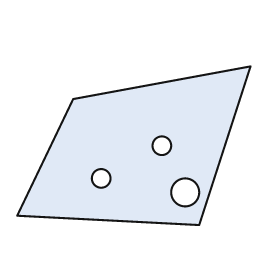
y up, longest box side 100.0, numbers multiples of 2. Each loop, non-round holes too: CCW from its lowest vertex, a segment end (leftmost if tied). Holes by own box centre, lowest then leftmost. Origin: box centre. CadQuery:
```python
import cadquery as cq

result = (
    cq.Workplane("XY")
    .moveTo(28.0, -34.0)
    .lineTo(50.0, 34.0)
    .lineTo(-26.0, 20.0)
    .lineTo(-50.0, -30.0)
    .close()
    .moveTo(22.0, -20.0)
    .circle(6.0)
    .moveTo(-14.0, -14.0)
    .circle(4.0)
    .moveTo(12.0, 0.0)
    .circle(4.0)
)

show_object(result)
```